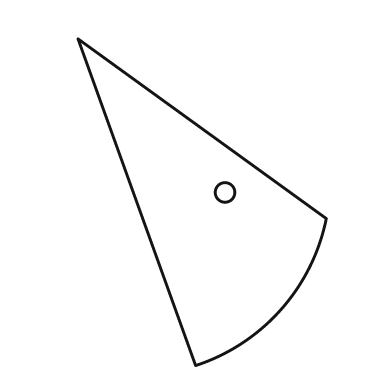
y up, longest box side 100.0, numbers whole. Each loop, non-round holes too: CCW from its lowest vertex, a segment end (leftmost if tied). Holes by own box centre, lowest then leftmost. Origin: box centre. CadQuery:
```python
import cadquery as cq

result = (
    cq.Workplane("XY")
    .moveTo(-2.0, -50.0)
    .threePointArc((24.0, -33.0), (38.0, -5.0))
    .lineTo(-38.0, 50.0)
    .close()
    .moveTo(7.0, 3.0)
    .circle(3.0)
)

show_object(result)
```